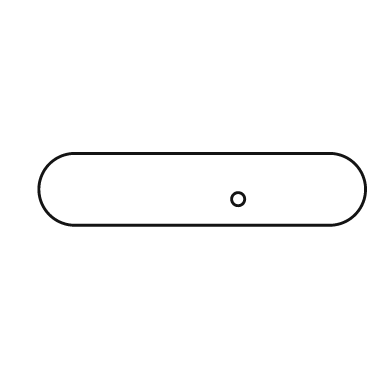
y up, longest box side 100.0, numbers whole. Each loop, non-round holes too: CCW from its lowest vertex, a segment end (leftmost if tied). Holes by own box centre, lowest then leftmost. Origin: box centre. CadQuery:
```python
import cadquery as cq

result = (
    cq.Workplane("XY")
    .moveTo(-39.0, -11.0)
    .lineTo(39.0, -11.0)
    .threePointArc((50.0, 0.0), (39.0, 11.0))
    .lineTo(-39.0, 11.0)
    .threePointArc((-50.0, 0.0), (-39.0, -11.0))
    .close()
    .moveTo(11.0, -3.0)
    .circle(2.0)
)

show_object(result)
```